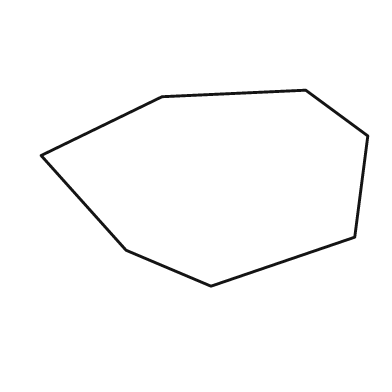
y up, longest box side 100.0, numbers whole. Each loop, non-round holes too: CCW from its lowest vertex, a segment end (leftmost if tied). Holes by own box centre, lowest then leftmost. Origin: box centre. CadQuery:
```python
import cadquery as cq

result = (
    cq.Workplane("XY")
    .moveTo(2.0, -30.0)
    .lineTo(46.0, -15.0)
    .lineTo(50.0, 16.0)
    .lineTo(31.0, 30.0)
    .lineTo(-13.0, 28.0)
    .lineTo(-50.0, 10.0)
    .lineTo(-24.0, -19.0)
    .close()
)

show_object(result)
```